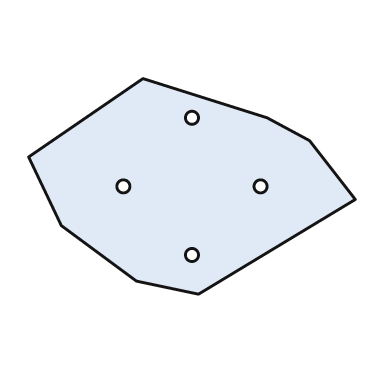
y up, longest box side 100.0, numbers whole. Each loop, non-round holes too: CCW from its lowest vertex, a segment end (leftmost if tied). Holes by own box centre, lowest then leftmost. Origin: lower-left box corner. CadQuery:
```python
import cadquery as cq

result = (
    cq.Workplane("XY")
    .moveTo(52.0, 0.0)
    .lineTo(100.0, 29.0)
    .lineTo(86.0, 47.0)
    .lineTo(73.0, 54.0)
    .lineTo(35.0, 66.0)
    .lineTo(0.0, 42.0)
    .lineTo(10.0, 21.0)
    .lineTo(33.0, 4.0)
    .close()
    .moveTo(50.0, 12.0)
    .circle(2.0)
    .moveTo(29.0, 33.0)
    .circle(2.0)
    .moveTo(71.0, 33.0)
    .circle(2.0)
    .moveTo(50.0, 54.0)
    .circle(2.0)
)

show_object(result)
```